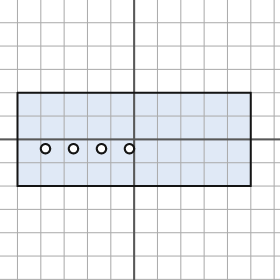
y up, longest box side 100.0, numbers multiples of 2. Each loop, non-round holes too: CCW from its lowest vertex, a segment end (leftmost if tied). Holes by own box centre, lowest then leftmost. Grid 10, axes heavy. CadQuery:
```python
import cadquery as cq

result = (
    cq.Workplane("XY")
    .moveTo(-50.0, -20.0)
    .lineTo(50.0, -20.0)
    .lineTo(50.0, 20.0)
    .lineTo(-50.0, 20.0)
    .close()
    .moveTo(-38.0, -4.0)
    .circle(2.0)
    .moveTo(-26.0, -4.0)
    .circle(2.0)
    .moveTo(-14.0, -4.0)
    .circle(2.0)
    .moveTo(-2.0, -4.0)
    .circle(2.0)
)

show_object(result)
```